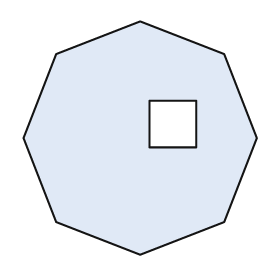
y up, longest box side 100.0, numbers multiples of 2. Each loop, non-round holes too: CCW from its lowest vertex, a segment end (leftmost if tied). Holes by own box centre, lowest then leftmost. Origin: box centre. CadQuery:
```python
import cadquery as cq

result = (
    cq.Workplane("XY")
    .moveTo(0.0, -50.0)
    .lineTo(36.0, -36.0)
    .lineTo(50.0, 0.0)
    .lineTo(36.0, 36.0)
    .lineTo(0.0, 50.0)
    .lineTo(-36.0, 36.0)
    .lineTo(-50.0, 0.0)
    .lineTo(-36.0, -36.0)
    .close()
    .moveTo(4.0, -4.0)
    .lineTo(24.0, -4.0)
    .lineTo(24.0, 16.0)
    .lineTo(4.0, 16.0)
    .close()
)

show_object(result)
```